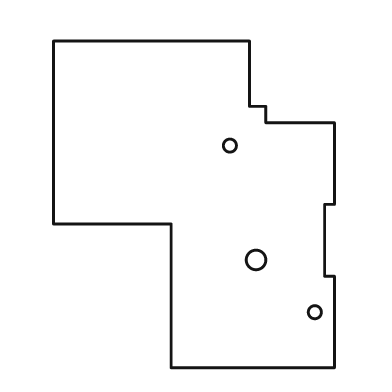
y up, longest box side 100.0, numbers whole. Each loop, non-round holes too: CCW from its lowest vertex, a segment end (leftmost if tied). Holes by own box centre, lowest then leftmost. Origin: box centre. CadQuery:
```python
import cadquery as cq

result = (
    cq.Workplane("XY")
    .moveTo(-7.0, -50.0)
    .lineTo(43.0, -50.0)
    .lineTo(43.0, -22.0)
    .lineTo(40.0, -22.0)
    .lineTo(40.0, 0.0)
    .lineTo(43.0, 0.0)
    .lineTo(43.0, 25.0)
    .lineTo(22.0, 25.0)
    .lineTo(22.0, 30.0)
    .lineTo(17.0, 30.0)
    .lineTo(17.0, 50.0)
    .lineTo(-43.0, 50.0)
    .lineTo(-43.0, -6.0)
    .lineTo(-7.0, -6.0)
    .close()
    .moveTo(37.0, -33.0)
    .circle(2.0)
    .moveTo(19.0, -17.0)
    .circle(3.0)
    .moveTo(11.0, 18.0)
    .circle(2.0)
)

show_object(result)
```